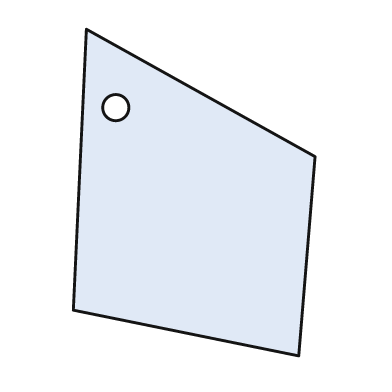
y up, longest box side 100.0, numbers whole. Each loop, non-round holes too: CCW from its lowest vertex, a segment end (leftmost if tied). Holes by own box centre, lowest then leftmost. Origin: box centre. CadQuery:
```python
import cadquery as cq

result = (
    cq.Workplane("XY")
    .moveTo(32.0, -50.0)
    .lineTo(37.0, 11.0)
    .lineTo(-33.0, 50.0)
    .lineTo(-37.0, -36.0)
    .close()
    .moveTo(-24.0, 26.0)
    .circle(4.0)
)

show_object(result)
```